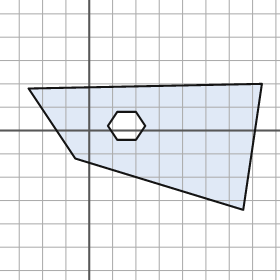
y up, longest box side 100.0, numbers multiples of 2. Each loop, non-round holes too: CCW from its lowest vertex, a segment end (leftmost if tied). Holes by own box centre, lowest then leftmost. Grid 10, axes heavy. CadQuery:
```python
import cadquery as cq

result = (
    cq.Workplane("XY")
    .moveTo(66.0, -34.0)
    .lineTo(74.0, 20.0)
    .lineTo(-26.0, 18.0)
    .lineTo(-6.0, -12.0)
    .close()
    .moveTo(12.0, -4.0)
    .lineTo(20.0, -4.0)
    .lineTo(24.0, 2.0)
    .lineTo(20.0, 8.0)
    .lineTo(12.0, 8.0)
    .lineTo(8.0, 2.0)
    .close()
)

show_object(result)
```